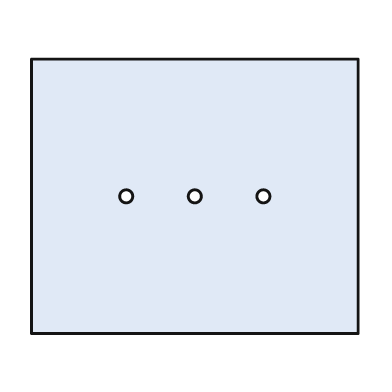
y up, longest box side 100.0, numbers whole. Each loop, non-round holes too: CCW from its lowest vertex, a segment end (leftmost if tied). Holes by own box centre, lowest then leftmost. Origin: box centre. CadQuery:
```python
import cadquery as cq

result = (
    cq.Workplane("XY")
    .moveTo(-50.0, -42.0)
    .lineTo(50.0, -42.0)
    .lineTo(50.0, 42.0)
    .lineTo(-50.0, 42.0)
    .close()
    .moveTo(-21.0, 0.0)
    .circle(2.0)
    .moveTo(0.0, 0.0)
    .circle(2.0)
    .moveTo(21.0, 0.0)
    .circle(2.0)
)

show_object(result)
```